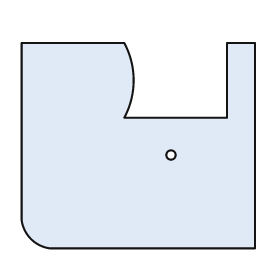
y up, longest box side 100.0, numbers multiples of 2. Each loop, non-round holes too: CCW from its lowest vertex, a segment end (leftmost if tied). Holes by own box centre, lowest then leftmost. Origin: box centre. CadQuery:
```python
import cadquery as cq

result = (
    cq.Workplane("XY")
    .moveTo(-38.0, -44.0)
    .lineTo(50.0, -44.0)
    .lineTo(50.0, 44.0)
    .lineTo(38.0, 44.0)
    .lineTo(38.0, 12.0)
    .lineTo(-6.0, 12.0)
    .threePointArc((-2.0, 28.0), (-6.0, 44.0))
    .lineTo(-50.0, 44.0)
    .lineTo(-50.0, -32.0)
    .threePointArc((-46.0, -40.0), (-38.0, -44.0))
    .close()
    .moveTo(14.0, -4.0)
    .circle(2.0)
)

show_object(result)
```